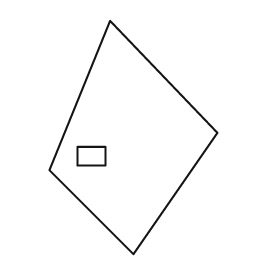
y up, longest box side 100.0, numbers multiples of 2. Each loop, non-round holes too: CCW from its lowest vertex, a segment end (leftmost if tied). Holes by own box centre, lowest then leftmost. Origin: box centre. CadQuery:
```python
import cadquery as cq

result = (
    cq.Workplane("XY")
    .moveTo(0.0, -50.0)
    .lineTo(36.0, 2.0)
    .lineTo(-10.0, 50.0)
    .lineTo(-36.0, -14.0)
    .close()
    .moveTo(-24.0, -12.0)
    .lineTo(-12.0, -12.0)
    .lineTo(-12.0, -4.0)
    .lineTo(-24.0, -4.0)
    .close()
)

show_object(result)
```